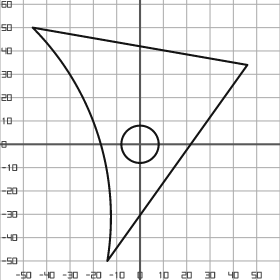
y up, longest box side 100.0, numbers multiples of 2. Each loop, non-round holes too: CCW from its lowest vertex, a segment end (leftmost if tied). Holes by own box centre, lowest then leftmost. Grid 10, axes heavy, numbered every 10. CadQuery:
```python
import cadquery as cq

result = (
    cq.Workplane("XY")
    .moveTo(-14.0, -50.0)
    .lineTo(46.0, 34.0)
    .lineTo(-46.0, 50.0)
    .threePointArc((-18.0, 4.0), (-14.0, -50.0))
    .close()
    .moveTo(0.0, 0.0)
    .circle(8.0)
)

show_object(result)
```